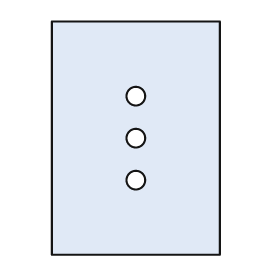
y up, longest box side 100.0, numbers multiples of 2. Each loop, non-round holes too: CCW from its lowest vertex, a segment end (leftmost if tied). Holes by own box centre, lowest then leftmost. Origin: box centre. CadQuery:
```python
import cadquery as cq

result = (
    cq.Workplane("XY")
    .moveTo(-36.0, -50.0)
    .lineTo(36.0, -50.0)
    .lineTo(36.0, 50.0)
    .lineTo(-36.0, 50.0)
    .close()
    .moveTo(0.0, -18.0)
    .circle(4.0)
    .moveTo(0.0, 0.0)
    .circle(4.0)
    .moveTo(0.0, 18.0)
    .circle(4.0)
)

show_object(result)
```